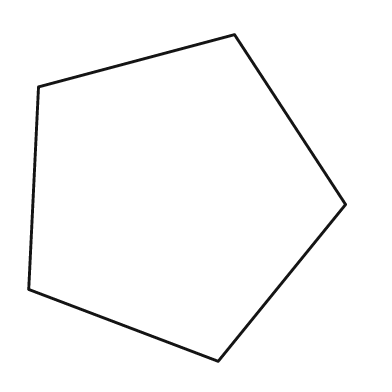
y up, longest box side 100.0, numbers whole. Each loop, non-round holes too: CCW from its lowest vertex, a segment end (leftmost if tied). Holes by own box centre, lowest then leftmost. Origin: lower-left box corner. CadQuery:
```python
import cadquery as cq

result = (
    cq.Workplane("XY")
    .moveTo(58.0, 0.0)
    .lineTo(97.0, 48.0)
    .lineTo(63.0, 100.0)
    .lineTo(3.0, 84.0)
    .lineTo(0.0, 22.0)
    .close()
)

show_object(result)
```